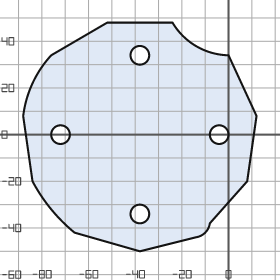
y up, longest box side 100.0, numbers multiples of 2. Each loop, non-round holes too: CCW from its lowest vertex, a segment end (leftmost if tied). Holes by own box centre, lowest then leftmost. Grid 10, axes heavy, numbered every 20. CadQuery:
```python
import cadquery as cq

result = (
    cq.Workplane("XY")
    .moveTo(-38.0, -50.0)
    .lineTo(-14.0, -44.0)
    .threePointArc((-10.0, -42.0), (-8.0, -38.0))
    .lineTo(8.0, -20.0)
    .lineTo(12.0, 8.0)
    .lineTo(0.0, 34.0)
    .threePointArc((-14.0, 38.0), (-24.0, 48.0))
    .lineTo(-52.0, 48.0)
    .lineTo(-76.0, 34.0)
    .threePointArc((-84.0, 22.0), (-88.0, 8.0))
    .lineTo(-84.0, -20.0)
    .threePointArc((-76.0, -32.0), (-66.0, -42.0))
    .close()
    .moveTo(-38.0, -34.0)
    .circle(4.0)
    .moveTo(-72.0, 0.0)
    .circle(4.0)
    .moveTo(-4.0, 0.0)
    .circle(4.0)
    .moveTo(-38.0, 34.0)
    .circle(4.0)
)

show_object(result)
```